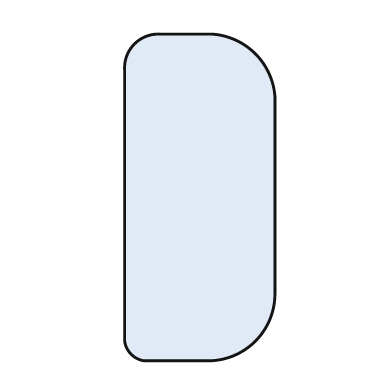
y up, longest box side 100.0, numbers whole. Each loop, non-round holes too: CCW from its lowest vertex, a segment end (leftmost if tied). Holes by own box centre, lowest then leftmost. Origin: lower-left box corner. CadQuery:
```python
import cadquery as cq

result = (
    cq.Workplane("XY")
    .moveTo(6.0, 0.0)
    .lineTo(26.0, 0.0)
    .threePointArc((40.0, 6.0), (46.0, 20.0))
    .lineTo(46.0, 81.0)
    .threePointArc((40.0, 94.0), (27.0, 100.0))
    .lineTo(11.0, 100.0)
    .threePointArc((3.0, 97.0), (0.0, 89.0))
    .lineTo(0.0, 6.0)
    .threePointArc((2.0, 2.0), (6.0, 0.0))
    .close()
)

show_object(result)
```